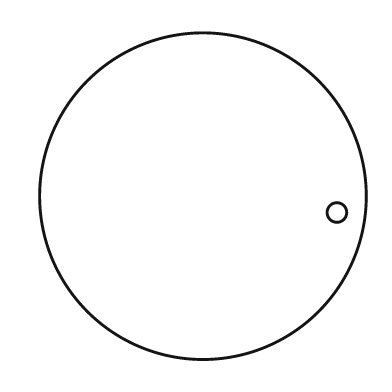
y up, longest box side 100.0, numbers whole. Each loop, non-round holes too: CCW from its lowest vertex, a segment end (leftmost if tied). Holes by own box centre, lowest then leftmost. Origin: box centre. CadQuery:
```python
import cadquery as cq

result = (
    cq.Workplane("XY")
    .moveTo(0.0, 0.0)
    .circle(50.0)
    .moveTo(41.0, -5.0)
    .circle(3.0)
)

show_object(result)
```